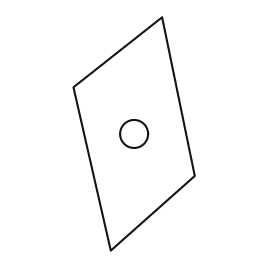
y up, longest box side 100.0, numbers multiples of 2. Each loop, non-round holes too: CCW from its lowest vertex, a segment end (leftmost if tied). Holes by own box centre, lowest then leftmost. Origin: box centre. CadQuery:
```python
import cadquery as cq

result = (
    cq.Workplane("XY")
    .moveTo(-10.0, -50.0)
    .lineTo(26.0, -18.0)
    .lineTo(12.0, 50.0)
    .lineTo(-26.0, 20.0)
    .close()
    .moveTo(0.0, 0.0)
    .circle(6.0)
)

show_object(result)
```